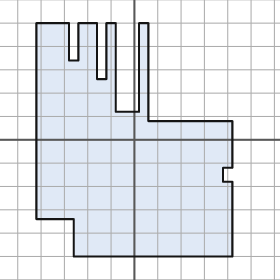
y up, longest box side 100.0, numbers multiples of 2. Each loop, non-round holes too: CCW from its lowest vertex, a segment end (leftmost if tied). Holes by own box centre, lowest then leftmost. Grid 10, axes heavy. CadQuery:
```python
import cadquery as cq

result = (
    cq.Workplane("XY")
    .moveTo(-26.0, -50.0)
    .lineTo(42.0, -50.0)
    .lineTo(42.0, -18.0)
    .lineTo(38.0, -18.0)
    .lineTo(38.0, -12.0)
    .lineTo(42.0, -12.0)
    .lineTo(42.0, 8.0)
    .lineTo(6.0, 8.0)
    .lineTo(6.0, 50.0)
    .lineTo(2.0, 50.0)
    .lineTo(2.0, 12.0)
    .lineTo(-8.0, 12.0)
    .lineTo(-8.0, 50.0)
    .lineTo(-12.0, 50.0)
    .lineTo(-12.0, 26.0)
    .lineTo(-16.0, 26.0)
    .lineTo(-16.0, 50.0)
    .lineTo(-24.0, 50.0)
    .lineTo(-24.0, 34.0)
    .lineTo(-28.0, 34.0)
    .lineTo(-28.0, 50.0)
    .lineTo(-42.0, 50.0)
    .lineTo(-42.0, -34.0)
    .lineTo(-26.0, -34.0)
    .close()
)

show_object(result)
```